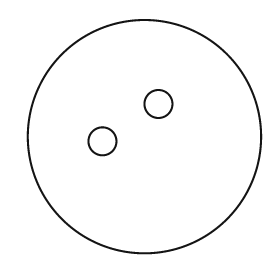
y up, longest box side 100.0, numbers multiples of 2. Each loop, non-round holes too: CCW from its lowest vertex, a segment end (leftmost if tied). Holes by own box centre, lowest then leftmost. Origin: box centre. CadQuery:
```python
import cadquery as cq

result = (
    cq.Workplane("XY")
    .moveTo(0.0, 0.0)
    .circle(50.0)
    .moveTo(-18.0, -2.0)
    .circle(6.0)
    .moveTo(6.0, 14.0)
    .circle(6.0)
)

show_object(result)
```